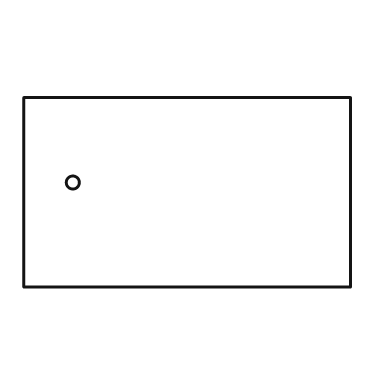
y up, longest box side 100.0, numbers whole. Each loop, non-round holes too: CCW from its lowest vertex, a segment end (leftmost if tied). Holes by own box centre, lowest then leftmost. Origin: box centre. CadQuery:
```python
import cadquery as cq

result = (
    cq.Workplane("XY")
    .moveTo(-50.0, -29.0)
    .lineTo(50.0, -29.0)
    .lineTo(50.0, 29.0)
    .lineTo(-50.0, 29.0)
    .close()
    .moveTo(-35.0, 3.0)
    .circle(2.0)
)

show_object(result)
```